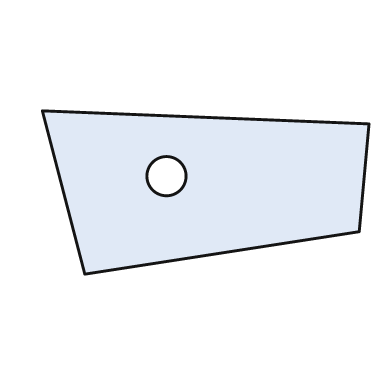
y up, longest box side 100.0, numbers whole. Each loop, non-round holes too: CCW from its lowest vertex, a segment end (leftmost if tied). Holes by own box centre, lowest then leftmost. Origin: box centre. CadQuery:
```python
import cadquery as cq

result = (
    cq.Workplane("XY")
    .moveTo(-37.0, -25.0)
    .lineTo(47.0, -12.0)
    .lineTo(50.0, 21.0)
    .lineTo(-50.0, 25.0)
    .close()
    .moveTo(-12.0, 5.0)
    .circle(6.0)
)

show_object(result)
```